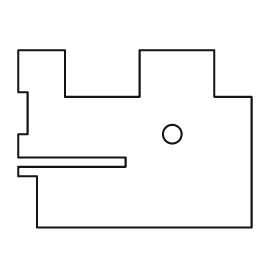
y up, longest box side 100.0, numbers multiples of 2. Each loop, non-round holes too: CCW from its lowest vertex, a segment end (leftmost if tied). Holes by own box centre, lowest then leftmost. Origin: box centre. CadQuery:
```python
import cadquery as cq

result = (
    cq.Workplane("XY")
    .moveTo(-42.0, -38.0)
    .lineTo(50.0, -38.0)
    .lineTo(50.0, 18.0)
    .lineTo(34.0, 18.0)
    .lineTo(34.0, 38.0)
    .lineTo(2.0, 38.0)
    .lineTo(2.0, 18.0)
    .lineTo(-30.0, 18.0)
    .lineTo(-30.0, 38.0)
    .lineTo(-50.0, 38.0)
    .lineTo(-50.0, 20.0)
    .lineTo(-46.0, 20.0)
    .lineTo(-46.0, 2.0)
    .lineTo(-50.0, 2.0)
    .lineTo(-50.0, -8.0)
    .lineTo(-4.0, -8.0)
    .lineTo(-4.0, -12.0)
    .lineTo(-50.0, -12.0)
    .lineTo(-50.0, -16.0)
    .lineTo(-42.0, -16.0)
    .close()
    .moveTo(16.0, 2.0)
    .circle(4.0)
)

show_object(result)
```